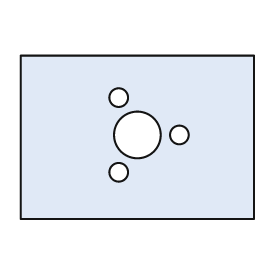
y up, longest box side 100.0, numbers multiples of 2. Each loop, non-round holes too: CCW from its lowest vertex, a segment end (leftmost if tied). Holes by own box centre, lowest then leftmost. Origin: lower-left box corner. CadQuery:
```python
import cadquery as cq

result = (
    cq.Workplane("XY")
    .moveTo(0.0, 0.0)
    .lineTo(100.0, 0.0)
    .lineTo(100.0, 70.0)
    .lineTo(0.0, 70.0)
    .close()
    .moveTo(42.0, 20.0)
    .circle(4.0)
    .moveTo(50.0, 36.0)
    .circle(10.0)
    .moveTo(68.0, 36.0)
    .circle(4.0)
    .moveTo(42.0, 52.0)
    .circle(4.0)
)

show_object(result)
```